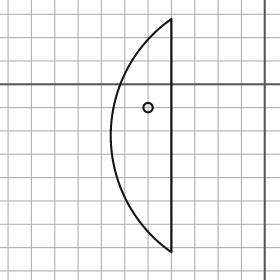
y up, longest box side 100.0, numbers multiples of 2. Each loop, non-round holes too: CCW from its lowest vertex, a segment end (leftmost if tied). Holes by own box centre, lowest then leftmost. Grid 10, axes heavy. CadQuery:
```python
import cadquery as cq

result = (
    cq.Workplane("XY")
    .moveTo(-40.0, -72.0)
    .lineTo(-40.0, 28.0)
    .threePointArc((-66.0, -22.0), (-40.0, -72.0))
    .close()
    .moveTo(-50.0, -10.0)
    .circle(2.0)
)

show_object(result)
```